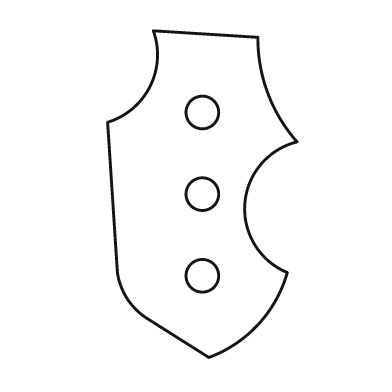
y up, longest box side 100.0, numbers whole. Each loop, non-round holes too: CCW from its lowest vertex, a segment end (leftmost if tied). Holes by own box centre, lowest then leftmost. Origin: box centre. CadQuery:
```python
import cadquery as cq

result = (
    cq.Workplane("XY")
    .moveTo(2.0, -50.0)
    .threePointArc((17.0, -40.0), (26.0, -24.0))
    .threePointArc((13.0, -3.0), (29.0, 16.0))
    .threePointArc((20.0, 31.0), (17.0, 48.0))
    .lineTo(-15.0, 50.0)
    .threePointArc((-16.0, 33.0), (-29.0, 22.0))
    .lineTo(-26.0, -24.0)
    .threePointArc((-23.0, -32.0), (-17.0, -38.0))
    .close()
    .moveTo(0.0, -25.0)
    .circle(5.0)
    .moveTo(0.0, 0.0)
    .circle(5.0)
    .moveTo(0.0, 25.0)
    .circle(5.0)
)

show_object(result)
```